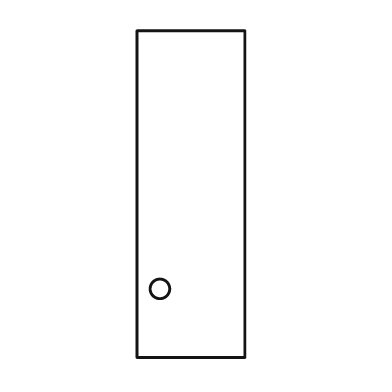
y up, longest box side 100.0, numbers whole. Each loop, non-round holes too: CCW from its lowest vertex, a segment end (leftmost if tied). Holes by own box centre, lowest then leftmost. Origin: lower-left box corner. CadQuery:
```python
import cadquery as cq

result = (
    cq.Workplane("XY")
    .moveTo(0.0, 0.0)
    .lineTo(33.0, 0.0)
    .lineTo(33.0, 100.0)
    .lineTo(0.0, 100.0)
    .close()
    .moveTo(7.0, 21.0)
    .circle(3.0)
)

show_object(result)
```